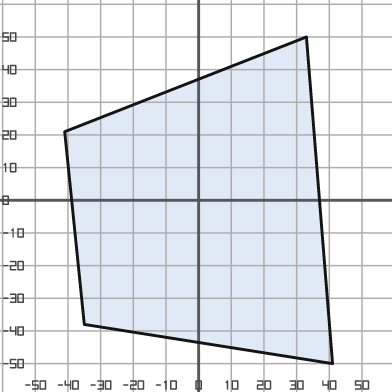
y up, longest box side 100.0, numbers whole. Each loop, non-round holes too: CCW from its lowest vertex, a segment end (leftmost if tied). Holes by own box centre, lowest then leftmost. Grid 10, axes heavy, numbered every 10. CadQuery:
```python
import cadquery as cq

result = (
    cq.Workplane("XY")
    .moveTo(41.0, -50.0)
    .lineTo(33.0, 50.0)
    .lineTo(-41.0, 21.0)
    .lineTo(-35.0, -38.0)
    .close()
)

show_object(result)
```